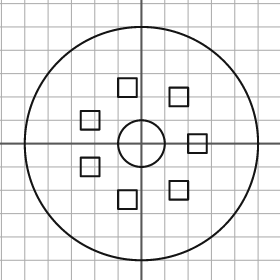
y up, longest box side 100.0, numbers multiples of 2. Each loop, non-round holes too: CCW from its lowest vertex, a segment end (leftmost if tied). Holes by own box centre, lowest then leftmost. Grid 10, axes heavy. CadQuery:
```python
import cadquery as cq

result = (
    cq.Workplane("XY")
    .moveTo(0.0, 0.0)
    .circle(50.0)
    .moveTo(-10.0, -28.0)
    .lineTo(-2.0, -28.0)
    .lineTo(-2.0, -20.0)
    .lineTo(-10.0, -20.0)
    .close()
    .moveTo(12.0, -24.0)
    .lineTo(20.0, -24.0)
    .lineTo(20.0, -16.0)
    .lineTo(12.0, -16.0)
    .close()
    .moveTo(-26.0, -14.0)
    .lineTo(-18.0, -14.0)
    .lineTo(-18.0, -6.0)
    .lineTo(-26.0, -6.0)
    .close()
    .moveTo(0.0, 0.0)
    .circle(10.0)
    .moveTo(20.0, -4.0)
    .lineTo(28.0, -4.0)
    .lineTo(28.0, 4.0)
    .lineTo(20.0, 4.0)
    .close()
    .moveTo(-26.0, 6.0)
    .lineTo(-18.0, 6.0)
    .lineTo(-18.0, 14.0)
    .lineTo(-26.0, 14.0)
    .close()
    .moveTo(12.0, 16.0)
    .lineTo(20.0, 16.0)
    .lineTo(20.0, 24.0)
    .lineTo(12.0, 24.0)
    .close()
    .moveTo(-10.0, 20.0)
    .lineTo(-2.0, 20.0)
    .lineTo(-2.0, 28.0)
    .lineTo(-10.0, 28.0)
    .close()
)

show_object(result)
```